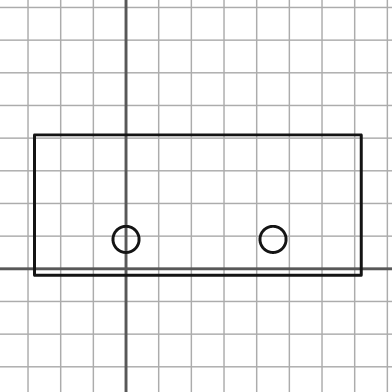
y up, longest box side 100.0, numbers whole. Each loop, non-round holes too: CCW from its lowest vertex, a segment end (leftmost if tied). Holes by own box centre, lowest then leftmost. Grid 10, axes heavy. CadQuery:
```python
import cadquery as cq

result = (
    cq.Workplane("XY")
    .moveTo(-28.0, -2.0)
    .lineTo(72.0, -2.0)
    .lineTo(72.0, 41.0)
    .lineTo(-28.0, 41.0)
    .close()
    .moveTo(0.0, 9.0)
    .circle(4.0)
    .moveTo(45.0, 9.0)
    .circle(4.0)
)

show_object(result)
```